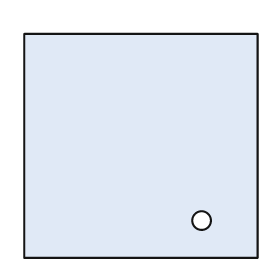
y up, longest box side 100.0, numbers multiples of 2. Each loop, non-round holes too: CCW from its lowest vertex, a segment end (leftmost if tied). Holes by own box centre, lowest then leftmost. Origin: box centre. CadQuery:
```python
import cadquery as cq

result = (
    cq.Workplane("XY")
    .moveTo(-50.0, -48.0)
    .lineTo(50.0, -48.0)
    .lineTo(50.0, 48.0)
    .lineTo(-50.0, 48.0)
    .close()
    .moveTo(26.0, -32.0)
    .circle(4.0)
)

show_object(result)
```